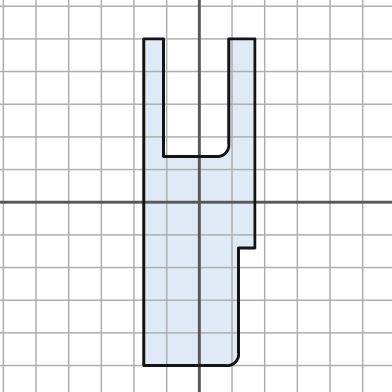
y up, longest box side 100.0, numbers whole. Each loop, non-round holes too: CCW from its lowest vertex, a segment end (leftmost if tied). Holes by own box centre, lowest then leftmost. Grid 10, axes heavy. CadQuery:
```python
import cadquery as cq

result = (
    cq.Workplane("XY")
    .moveTo(-17.0, -50.0)
    .lineTo(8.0, -50.0)
    .threePointArc((11.0, -49.0), (12.0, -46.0))
    .lineTo(12.0, -14.0)
    .lineTo(17.0, -14.0)
    .lineTo(17.0, 50.0)
    .lineTo(9.0, 50.0)
    .lineTo(9.0, 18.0)
    .threePointArc((8.0, 15.0), (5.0, 14.0))
    .lineTo(-11.0, 14.0)
    .lineTo(-11.0, 50.0)
    .lineTo(-17.0, 50.0)
    .close()
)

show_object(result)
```